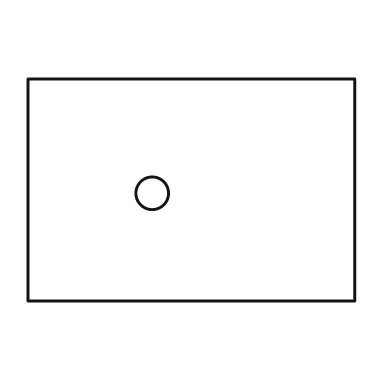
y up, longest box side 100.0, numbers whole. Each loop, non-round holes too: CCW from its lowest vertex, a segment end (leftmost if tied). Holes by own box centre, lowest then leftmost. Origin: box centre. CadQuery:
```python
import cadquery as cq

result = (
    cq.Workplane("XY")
    .moveTo(-50.0, -34.0)
    .lineTo(50.0, -34.0)
    .lineTo(50.0, 34.0)
    .lineTo(-50.0, 34.0)
    .close()
    .moveTo(-12.0, -1.0)
    .circle(5.0)
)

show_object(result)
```